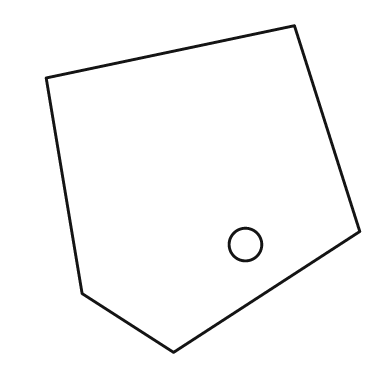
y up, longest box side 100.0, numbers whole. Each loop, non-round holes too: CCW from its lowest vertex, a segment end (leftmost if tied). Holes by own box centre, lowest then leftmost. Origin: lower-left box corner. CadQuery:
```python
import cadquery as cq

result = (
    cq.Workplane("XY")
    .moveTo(39.0, 0.0)
    .lineTo(96.0, 37.0)
    .lineTo(76.0, 100.0)
    .lineTo(0.0, 84.0)
    .lineTo(11.0, 18.0)
    .close()
    .moveTo(61.0, 33.0)
    .circle(5.0)
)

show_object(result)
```